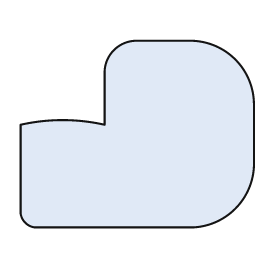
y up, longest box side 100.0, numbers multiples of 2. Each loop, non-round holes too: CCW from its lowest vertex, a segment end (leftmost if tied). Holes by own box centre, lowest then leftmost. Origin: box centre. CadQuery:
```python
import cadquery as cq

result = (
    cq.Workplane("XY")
    .moveTo(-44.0, -40.0)
    .lineTo(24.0, -40.0)
    .threePointArc((42.0, -32.0), (50.0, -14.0))
    .lineTo(50.0, 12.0)
    .threePointArc((42.0, 32.0), (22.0, 40.0))
    .lineTo(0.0, 40.0)
    .threePointArc((-10.0, 36.0), (-14.0, 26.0))
    .lineTo(-14.0, 4.0)
    .threePointArc((-32.0, 6.0), (-50.0, 4.0))
    .lineTo(-50.0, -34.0)
    .threePointArc((-48.0, -38.0), (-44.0, -40.0))
    .close()
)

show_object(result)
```